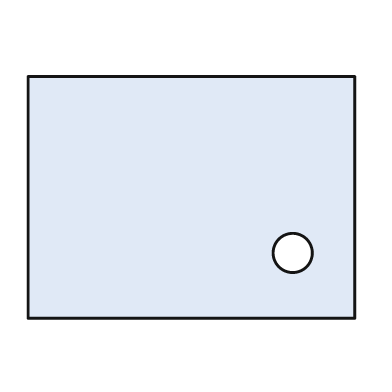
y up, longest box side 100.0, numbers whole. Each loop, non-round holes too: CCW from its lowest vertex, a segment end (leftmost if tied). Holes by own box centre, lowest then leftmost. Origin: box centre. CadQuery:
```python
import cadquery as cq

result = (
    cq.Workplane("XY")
    .moveTo(-50.0, -37.0)
    .lineTo(50.0, -37.0)
    .lineTo(50.0, 37.0)
    .lineTo(-50.0, 37.0)
    .close()
    .moveTo(31.0, -17.0)
    .circle(6.0)
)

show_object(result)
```